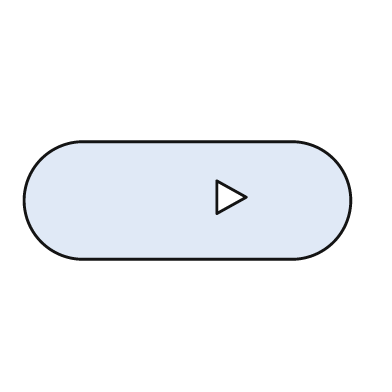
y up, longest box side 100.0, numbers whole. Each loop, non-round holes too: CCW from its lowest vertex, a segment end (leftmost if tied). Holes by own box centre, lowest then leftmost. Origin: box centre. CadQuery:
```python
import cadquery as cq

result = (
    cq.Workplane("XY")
    .moveTo(-32.0, -18.0)
    .lineTo(32.0, -18.0)
    .threePointArc((50.0, 0.0), (32.0, 18.0))
    .lineTo(-32.0, 18.0)
    .threePointArc((-50.0, 0.0), (-32.0, -18.0))
    .close()
    .moveTo(9.0, -4.0)
    .lineTo(18.0, 1.0)
    .lineTo(9.0, 6.0)
    .close()
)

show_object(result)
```